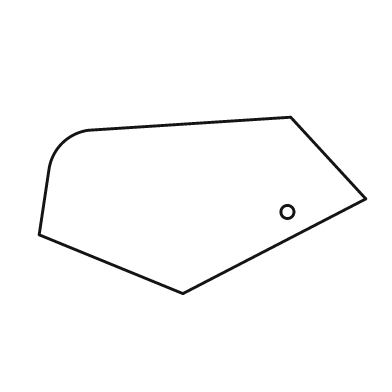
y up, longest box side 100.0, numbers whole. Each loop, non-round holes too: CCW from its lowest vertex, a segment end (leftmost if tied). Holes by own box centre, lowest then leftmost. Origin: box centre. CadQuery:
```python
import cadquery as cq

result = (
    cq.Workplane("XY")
    .moveTo(-6.0, -27.0)
    .lineTo(50.0, 2.0)
    .lineTo(27.0, 27.0)
    .lineTo(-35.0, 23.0)
    .threePointArc((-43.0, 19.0), (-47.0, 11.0))
    .lineTo(-50.0, -9.0)
    .close()
    .moveTo(26.0, -2.0)
    .circle(2.0)
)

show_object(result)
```